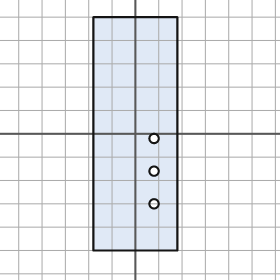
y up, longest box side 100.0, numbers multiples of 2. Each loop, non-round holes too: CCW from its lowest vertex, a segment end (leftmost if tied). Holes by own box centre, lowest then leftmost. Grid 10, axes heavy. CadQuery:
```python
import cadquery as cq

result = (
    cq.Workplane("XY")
    .moveTo(-18.0, -50.0)
    .lineTo(18.0, -50.0)
    .lineTo(18.0, 50.0)
    .lineTo(-18.0, 50.0)
    .close()
    .moveTo(8.0, -30.0)
    .circle(2.0)
    .moveTo(8.0, -16.0)
    .circle(2.0)
    .moveTo(8.0, -2.0)
    .circle(2.0)
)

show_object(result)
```